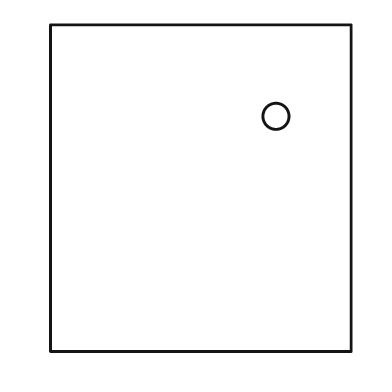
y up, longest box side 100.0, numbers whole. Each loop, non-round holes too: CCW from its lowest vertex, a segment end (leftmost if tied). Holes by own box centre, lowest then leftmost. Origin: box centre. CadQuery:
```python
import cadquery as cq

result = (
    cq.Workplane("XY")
    .moveTo(-46.0, -50.0)
    .lineTo(46.0, -50.0)
    .lineTo(46.0, 50.0)
    .lineTo(-46.0, 50.0)
    .close()
    .moveTo(23.0, 22.0)
    .circle(4.0)
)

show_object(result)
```